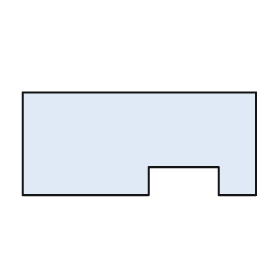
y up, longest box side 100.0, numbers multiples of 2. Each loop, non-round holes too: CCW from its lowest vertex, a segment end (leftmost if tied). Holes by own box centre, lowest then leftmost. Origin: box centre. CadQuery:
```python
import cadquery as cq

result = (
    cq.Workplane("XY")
    .moveTo(-50.0, -22.0)
    .lineTo(4.0, -22.0)
    .lineTo(4.0, -10.0)
    .lineTo(34.0, -10.0)
    .lineTo(34.0, -22.0)
    .lineTo(50.0, -22.0)
    .lineTo(50.0, 22.0)
    .lineTo(-50.0, 22.0)
    .close()
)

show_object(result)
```